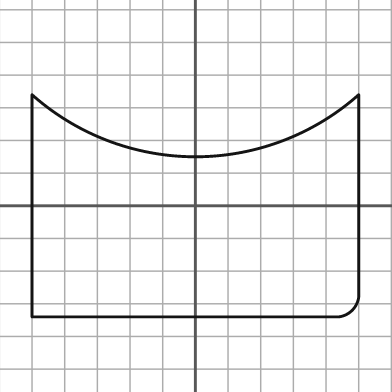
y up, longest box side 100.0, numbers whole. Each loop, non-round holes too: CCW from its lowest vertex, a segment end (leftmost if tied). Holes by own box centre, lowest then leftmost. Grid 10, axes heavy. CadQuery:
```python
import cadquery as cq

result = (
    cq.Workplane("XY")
    .moveTo(-50.0, -34.0)
    .lineTo(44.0, -34.0)
    .threePointArc((48.0, -32.0), (50.0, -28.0))
    .lineTo(50.0, 34.0)
    .threePointArc((0.0, 15.0), (-50.0, 34.0))
    .close()
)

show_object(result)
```